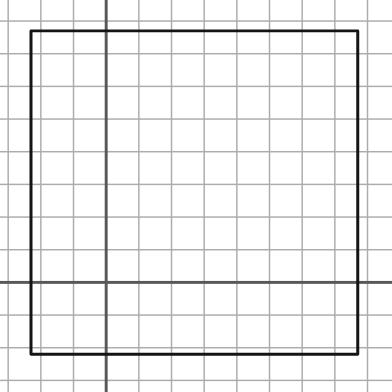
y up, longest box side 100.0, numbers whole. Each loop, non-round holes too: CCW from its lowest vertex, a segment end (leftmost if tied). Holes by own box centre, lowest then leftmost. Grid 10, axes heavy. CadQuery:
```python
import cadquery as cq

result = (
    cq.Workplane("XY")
    .moveTo(-23.0, -22.0)
    .lineTo(77.0, -22.0)
    .lineTo(77.0, 77.0)
    .lineTo(-23.0, 77.0)
    .close()
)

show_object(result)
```